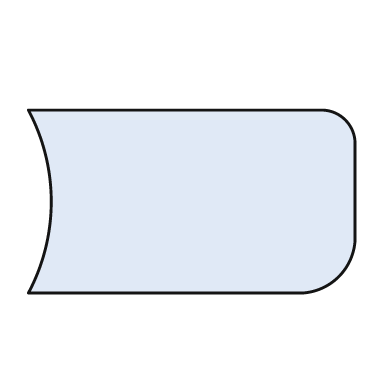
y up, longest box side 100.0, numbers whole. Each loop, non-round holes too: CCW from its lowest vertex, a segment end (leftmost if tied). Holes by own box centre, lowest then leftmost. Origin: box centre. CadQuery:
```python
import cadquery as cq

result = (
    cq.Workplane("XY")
    .moveTo(-50.0, -28.0)
    .lineTo(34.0, -28.0)
    .threePointArc((45.0, -23.0), (50.0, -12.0))
    .lineTo(50.0, 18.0)
    .threePointArc((47.0, 25.0), (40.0, 28.0))
    .lineTo(-50.0, 28.0)
    .threePointArc((-43.0, 0.0), (-50.0, -28.0))
    .close()
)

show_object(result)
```